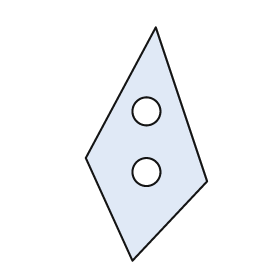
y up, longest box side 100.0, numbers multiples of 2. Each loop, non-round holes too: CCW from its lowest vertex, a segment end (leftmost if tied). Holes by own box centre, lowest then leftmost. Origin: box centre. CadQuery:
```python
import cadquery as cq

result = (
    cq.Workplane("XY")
    .moveTo(-6.0, -50.0)
    .lineTo(26.0, -16.0)
    .lineTo(4.0, 50.0)
    .lineTo(-26.0, -6.0)
    .close()
    .moveTo(0.0, -12.0)
    .circle(6.0)
    .moveTo(0.0, 14.0)
    .circle(6.0)
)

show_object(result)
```